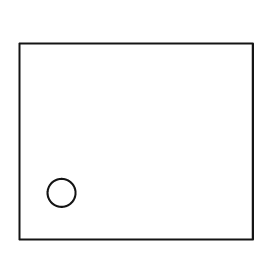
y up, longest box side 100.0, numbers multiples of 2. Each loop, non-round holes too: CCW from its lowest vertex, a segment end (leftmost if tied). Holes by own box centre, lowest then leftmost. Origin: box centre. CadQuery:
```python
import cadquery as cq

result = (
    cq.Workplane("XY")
    .moveTo(-50.0, -42.0)
    .lineTo(50.0, -42.0)
    .lineTo(50.0, 42.0)
    .lineTo(-50.0, 42.0)
    .close()
    .moveTo(-32.0, -22.0)
    .circle(6.0)
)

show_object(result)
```